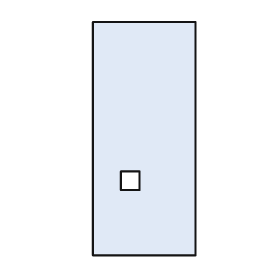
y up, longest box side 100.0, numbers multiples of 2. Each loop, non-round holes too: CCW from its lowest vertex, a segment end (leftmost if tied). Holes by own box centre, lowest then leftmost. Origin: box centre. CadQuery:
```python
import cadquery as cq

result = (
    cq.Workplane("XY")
    .moveTo(-22.0, -50.0)
    .lineTo(22.0, -50.0)
    .lineTo(22.0, 50.0)
    .lineTo(-22.0, 50.0)
    .close()
    .moveTo(-10.0, -22.0)
    .lineTo(-2.0, -22.0)
    .lineTo(-2.0, -14.0)
    .lineTo(-10.0, -14.0)
    .close()
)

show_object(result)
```